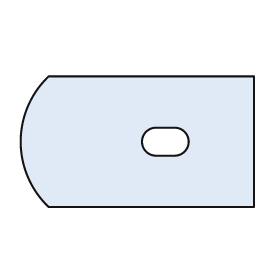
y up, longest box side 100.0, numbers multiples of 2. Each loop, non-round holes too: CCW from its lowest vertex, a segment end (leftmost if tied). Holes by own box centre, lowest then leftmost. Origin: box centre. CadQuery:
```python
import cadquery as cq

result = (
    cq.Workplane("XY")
    .moveTo(-38.0, -28.0)
    .lineTo(50.0, -28.0)
    .lineTo(50.0, 28.0)
    .lineTo(-38.0, 28.0)
    .threePointArc((-50.0, 0.0), (-38.0, -28.0))
    .close()
    .moveTo(8.0, -6.0)
    .lineTo(16.0, -6.0)
    .threePointArc((22.0, 0.0), (16.0, 6.0))
    .lineTo(8.0, 6.0)
    .threePointArc((2.0, 0.0), (8.0, -6.0))
    .close()
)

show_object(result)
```